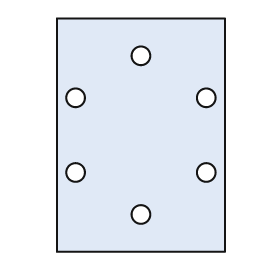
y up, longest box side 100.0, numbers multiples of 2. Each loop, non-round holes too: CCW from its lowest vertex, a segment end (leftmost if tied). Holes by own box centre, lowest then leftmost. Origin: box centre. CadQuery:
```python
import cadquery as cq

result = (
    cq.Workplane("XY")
    .moveTo(-36.0, -50.0)
    .lineTo(36.0, -50.0)
    .lineTo(36.0, 50.0)
    .lineTo(-36.0, 50.0)
    .close()
    .moveTo(0.0, -34.0)
    .circle(4.0)
    .moveTo(-28.0, -16.0)
    .circle(4.0)
    .moveTo(28.0, -16.0)
    .circle(4.0)
    .moveTo(-28.0, 16.0)
    .circle(4.0)
    .moveTo(28.0, 16.0)
    .circle(4.0)
    .moveTo(0.0, 34.0)
    .circle(4.0)
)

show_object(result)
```